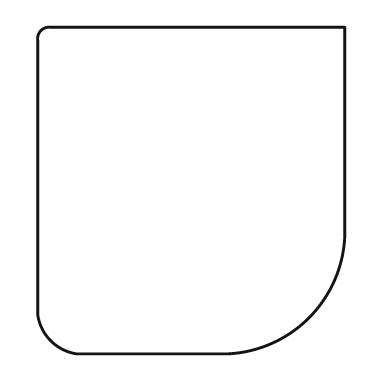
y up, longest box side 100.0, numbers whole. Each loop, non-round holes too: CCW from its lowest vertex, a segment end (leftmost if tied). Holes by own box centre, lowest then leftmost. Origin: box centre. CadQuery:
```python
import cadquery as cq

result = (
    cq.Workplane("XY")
    .moveTo(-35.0, -50.0)
    .lineTo(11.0, -50.0)
    .threePointArc((36.0, -39.0), (47.0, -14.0))
    .lineTo(47.0, 50.0)
    .lineTo(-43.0, 50.0)
    .threePointArc((-46.0, 49.0), (-47.0, 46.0))
    .lineTo(-47.0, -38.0)
    .threePointArc((-43.0, -46.0), (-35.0, -50.0))
    .close()
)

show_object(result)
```